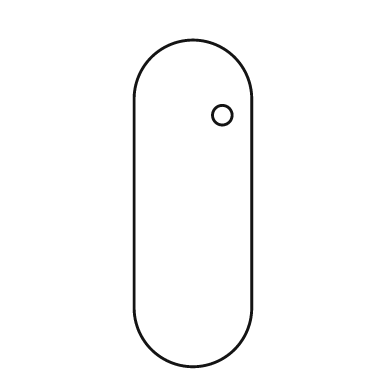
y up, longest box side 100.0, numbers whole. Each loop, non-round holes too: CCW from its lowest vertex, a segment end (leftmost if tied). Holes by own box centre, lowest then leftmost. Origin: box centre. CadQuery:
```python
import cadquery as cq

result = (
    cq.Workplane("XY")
    .moveTo(-18.0, -32.0)
    .threePointArc((0.0, -50.0), (18.0, -32.0))
    .lineTo(18.0, 32.0)
    .threePointArc((0.0, 50.0), (-18.0, 32.0))
    .close()
    .moveTo(9.0, 27.0)
    .circle(3.0)
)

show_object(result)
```